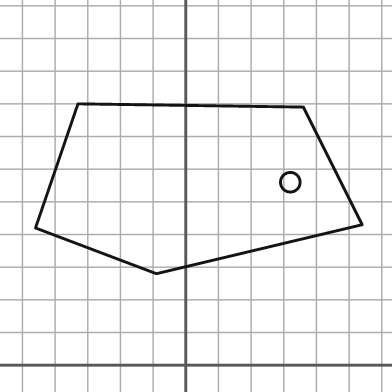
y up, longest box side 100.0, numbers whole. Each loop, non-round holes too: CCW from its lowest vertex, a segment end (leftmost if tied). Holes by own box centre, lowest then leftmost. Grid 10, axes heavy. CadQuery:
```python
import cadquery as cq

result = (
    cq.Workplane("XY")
    .moveTo(-9.0, 28.0)
    .lineTo(54.0, 43.0)
    .lineTo(36.0, 79.0)
    .lineTo(-33.0, 80.0)
    .lineTo(-46.0, 42.0)
    .close()
    .moveTo(32.0, 56.0)
    .circle(3.0)
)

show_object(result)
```